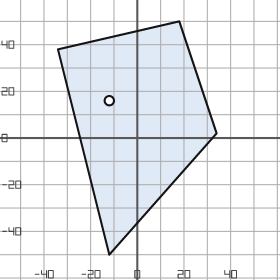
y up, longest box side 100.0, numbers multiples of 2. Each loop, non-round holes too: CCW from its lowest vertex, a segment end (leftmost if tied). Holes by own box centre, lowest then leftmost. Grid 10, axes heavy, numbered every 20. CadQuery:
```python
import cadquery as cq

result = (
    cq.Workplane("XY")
    .moveTo(-12.0, -50.0)
    .lineTo(34.0, 2.0)
    .lineTo(18.0, 50.0)
    .lineTo(-34.0, 38.0)
    .close()
    .moveTo(-12.0, 16.0)
    .circle(2.0)
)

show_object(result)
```